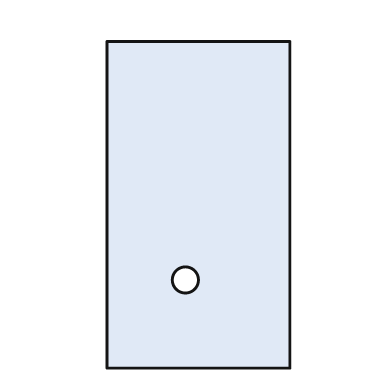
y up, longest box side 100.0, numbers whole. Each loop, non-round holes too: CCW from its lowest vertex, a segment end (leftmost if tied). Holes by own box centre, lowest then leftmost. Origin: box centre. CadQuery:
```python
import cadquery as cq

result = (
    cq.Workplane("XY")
    .moveTo(-28.0, -50.0)
    .lineTo(28.0, -50.0)
    .lineTo(28.0, 50.0)
    .lineTo(-28.0, 50.0)
    .close()
    .moveTo(-4.0, -23.0)
    .circle(4.0)
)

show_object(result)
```